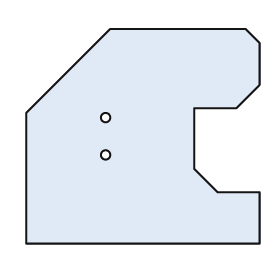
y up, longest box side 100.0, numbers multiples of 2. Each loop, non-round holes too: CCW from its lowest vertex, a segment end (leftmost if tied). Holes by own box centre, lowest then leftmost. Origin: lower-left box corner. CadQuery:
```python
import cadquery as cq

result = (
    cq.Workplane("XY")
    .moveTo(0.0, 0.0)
    .lineTo(100.0, 0.0)
    .lineTo(100.0, 22.0)
    .lineTo(82.0, 22.0)
    .lineTo(72.0, 32.0)
    .lineTo(72.0, 58.0)
    .lineTo(90.0, 58.0)
    .lineTo(100.0, 68.0)
    .lineTo(100.0, 86.0)
    .lineTo(94.0, 92.0)
    .lineTo(36.0, 92.0)
    .lineTo(0.0, 56.0)
    .close()
    .moveTo(34.0, 38.0)
    .circle(2.0)
    .moveTo(34.0, 54.0)
    .circle(2.0)
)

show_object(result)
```